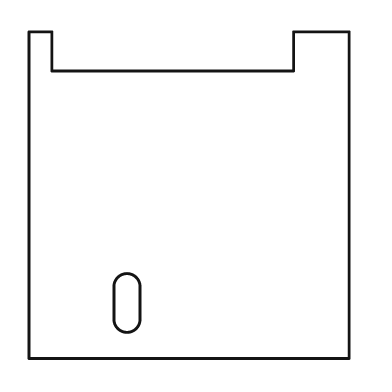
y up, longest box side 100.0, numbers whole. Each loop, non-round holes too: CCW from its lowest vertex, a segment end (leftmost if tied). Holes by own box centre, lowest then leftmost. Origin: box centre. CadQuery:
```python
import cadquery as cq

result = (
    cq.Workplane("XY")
    .moveTo(-49.0, -50.0)
    .lineTo(49.0, -50.0)
    .lineTo(49.0, 50.0)
    .lineTo(32.0, 50.0)
    .lineTo(32.0, 38.0)
    .lineTo(-42.0, 38.0)
    .lineTo(-42.0, 50.0)
    .lineTo(-49.0, 50.0)
    .close()
    .moveTo(-23.0, -38.0)
    .threePointArc((-19.0, -42.0), (-15.0, -38.0))
    .lineTo(-15.0, -28.0)
    .threePointArc((-19.0, -24.0), (-23.0, -28.0))
    .close()
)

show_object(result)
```